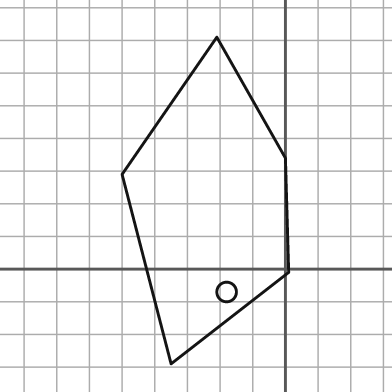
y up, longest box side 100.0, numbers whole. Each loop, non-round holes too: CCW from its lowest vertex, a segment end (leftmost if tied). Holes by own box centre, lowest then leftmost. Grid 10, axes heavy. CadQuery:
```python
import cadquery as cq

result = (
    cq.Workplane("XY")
    .moveTo(-35.0, -29.0)
    .lineTo(1.0, -1.0)
    .lineTo(0.0, 34.0)
    .lineTo(-21.0, 71.0)
    .lineTo(-50.0, 29.0)
    .close()
    .moveTo(-18.0, -7.0)
    .circle(3.0)
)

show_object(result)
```